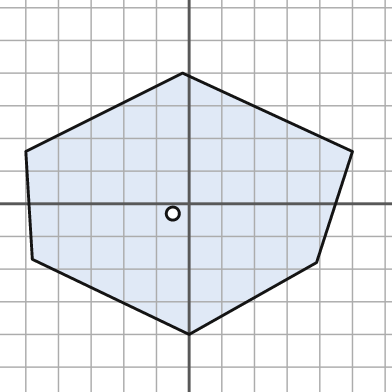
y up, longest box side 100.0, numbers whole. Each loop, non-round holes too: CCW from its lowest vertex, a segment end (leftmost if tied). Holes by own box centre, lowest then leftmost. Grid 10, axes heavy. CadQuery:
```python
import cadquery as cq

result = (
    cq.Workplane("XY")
    .moveTo(0.0, -40.0)
    .lineTo(39.0, -18.0)
    .lineTo(50.0, 16.0)
    .lineTo(-2.0, 40.0)
    .lineTo(-50.0, 16.0)
    .lineTo(-48.0, -17.0)
    .close()
    .moveTo(-5.0, -3.0)
    .circle(2.0)
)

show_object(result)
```